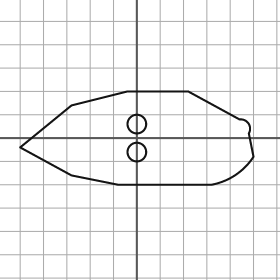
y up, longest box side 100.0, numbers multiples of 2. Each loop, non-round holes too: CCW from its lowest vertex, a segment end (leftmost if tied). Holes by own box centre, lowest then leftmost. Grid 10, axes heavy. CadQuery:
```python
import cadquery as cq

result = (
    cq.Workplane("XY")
    .moveTo(-8.0, -20.0)
    .lineTo(32.0, -20.0)
    .threePointArc((42.0, -16.0), (50.0, -8.0))
    .lineTo(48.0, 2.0)
    .threePointArc((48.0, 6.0), (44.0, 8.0))
    .lineTo(22.0, 20.0)
    .lineTo(-4.0, 20.0)
    .lineTo(-28.0, 14.0)
    .lineTo(-50.0, -4.0)
    .lineTo(-28.0, -16.0)
    .close()
    .moveTo(0.0, -6.0)
    .circle(4.0)
    .moveTo(0.0, 6.0)
    .circle(4.0)
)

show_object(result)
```